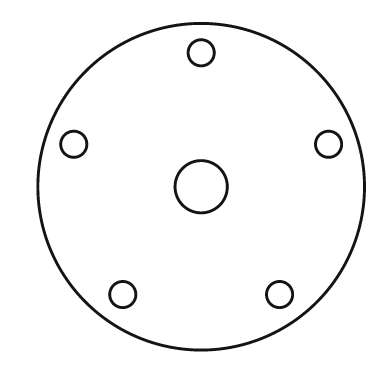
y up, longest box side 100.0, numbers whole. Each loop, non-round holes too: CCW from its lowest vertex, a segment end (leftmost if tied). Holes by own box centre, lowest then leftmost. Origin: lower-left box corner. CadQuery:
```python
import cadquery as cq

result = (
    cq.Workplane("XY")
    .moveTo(50.0, 50.0)
    .circle(50.0)
    .moveTo(26.0, 17.0)
    .circle(4.0)
    .moveTo(74.0, 17.0)
    .circle(4.0)
    .moveTo(50.0, 50.0)
    .circle(8.0)
    .moveTo(11.0, 63.0)
    .circle(4.0)
    .moveTo(89.0, 63.0)
    .circle(4.0)
    .moveTo(50.0, 91.0)
    .circle(4.0)
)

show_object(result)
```